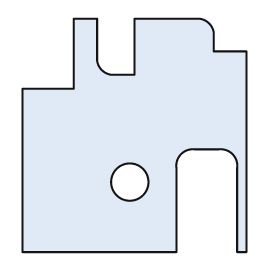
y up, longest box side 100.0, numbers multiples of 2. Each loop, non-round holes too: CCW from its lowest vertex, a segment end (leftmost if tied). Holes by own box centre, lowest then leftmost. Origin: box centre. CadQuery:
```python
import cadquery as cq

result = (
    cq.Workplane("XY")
    .moveTo(-48.0, -50.0)
    .lineTo(18.0, -50.0)
    .lineTo(18.0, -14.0)
    .threePointArc((20.0, -8.0), (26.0, -6.0))
    .lineTo(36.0, -6.0)
    .threePointArc((42.0, -8.0), (44.0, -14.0))
    .lineTo(44.0, -50.0)
    .lineTo(48.0, -50.0)
    .lineTo(48.0, 36.0)
    .lineTo(34.0, 36.0)
    .lineTo(34.0, 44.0)
    .threePointArc((32.0, 48.0), (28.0, 50.0))
    .lineTo(0.0, 50.0)
    .lineTo(0.0, 26.0)
    .lineTo(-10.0, 26.0)
    .threePointArc((-14.0, 28.0), (-16.0, 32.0))
    .lineTo(-16.0, 50.0)
    .lineTo(-26.0, 50.0)
    .lineTo(-26.0, 20.0)
    .lineTo(-48.0, 20.0)
    .close()
    .moveTo(-2.0, -20.0)
    .circle(8.0)
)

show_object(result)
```